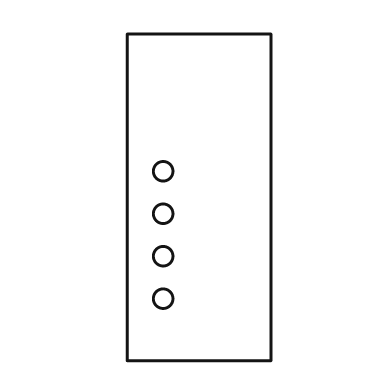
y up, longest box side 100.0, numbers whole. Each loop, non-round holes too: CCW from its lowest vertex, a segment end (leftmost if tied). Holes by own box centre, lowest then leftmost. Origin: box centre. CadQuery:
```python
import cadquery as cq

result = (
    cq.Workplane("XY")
    .moveTo(-22.0, -50.0)
    .lineTo(22.0, -50.0)
    .lineTo(22.0, 50.0)
    .lineTo(-22.0, 50.0)
    .close()
    .moveTo(-11.0, -31.0)
    .circle(3.0)
    .moveTo(-11.0, -18.0)
    .circle(3.0)
    .moveTo(-11.0, -5.0)
    .circle(3.0)
    .moveTo(-11.0, 8.0)
    .circle(3.0)
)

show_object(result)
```